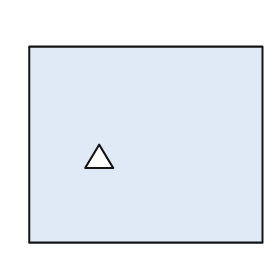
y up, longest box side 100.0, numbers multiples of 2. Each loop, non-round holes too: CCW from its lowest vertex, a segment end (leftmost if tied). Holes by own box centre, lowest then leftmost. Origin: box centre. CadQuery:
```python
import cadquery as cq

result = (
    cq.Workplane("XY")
    .moveTo(-50.0, -42.0)
    .lineTo(50.0, -42.0)
    .lineTo(50.0, 42.0)
    .lineTo(-50.0, 42.0)
    .close()
    .moveTo(-26.0, -10.0)
    .lineTo(-14.0, -10.0)
    .lineTo(-20.0, 0.0)
    .close()
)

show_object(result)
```